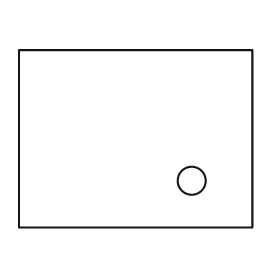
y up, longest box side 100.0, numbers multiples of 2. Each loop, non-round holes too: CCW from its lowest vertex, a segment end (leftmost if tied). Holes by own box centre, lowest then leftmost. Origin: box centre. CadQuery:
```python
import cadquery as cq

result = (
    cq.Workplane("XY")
    .moveTo(-50.0, -38.0)
    .lineTo(50.0, -38.0)
    .lineTo(50.0, 38.0)
    .lineTo(-50.0, 38.0)
    .close()
    .moveTo(24.0, -18.0)
    .circle(6.0)
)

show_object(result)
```